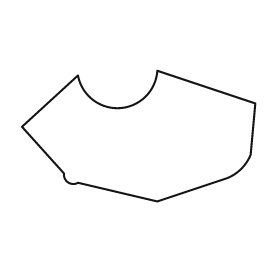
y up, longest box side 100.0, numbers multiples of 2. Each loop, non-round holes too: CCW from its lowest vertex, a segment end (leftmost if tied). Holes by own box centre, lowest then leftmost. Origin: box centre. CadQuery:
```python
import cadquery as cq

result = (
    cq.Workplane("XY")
    .moveTo(8.0, -28.0)
    .lineTo(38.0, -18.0)
    .threePointArc((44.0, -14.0), (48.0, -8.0))
    .lineTo(50.0, 14.0)
    .lineTo(8.0, 28.0)
    .threePointArc((-8.0, 12.0), (-26.0, 26.0))
    .lineTo(-50.0, 4.0)
    .lineTo(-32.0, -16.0)
    .threePointArc((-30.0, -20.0), (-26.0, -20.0))
    .close()
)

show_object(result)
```